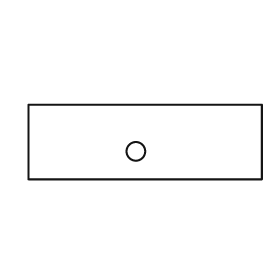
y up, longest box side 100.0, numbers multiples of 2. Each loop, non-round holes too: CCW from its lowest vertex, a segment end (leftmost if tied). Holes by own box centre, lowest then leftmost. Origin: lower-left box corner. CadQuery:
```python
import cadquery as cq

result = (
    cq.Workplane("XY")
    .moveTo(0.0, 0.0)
    .lineTo(100.0, 0.0)
    .lineTo(100.0, 32.0)
    .lineTo(0.0, 32.0)
    .close()
    .moveTo(46.0, 12.0)
    .circle(4.0)
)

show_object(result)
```